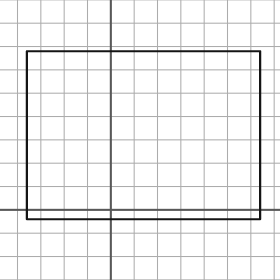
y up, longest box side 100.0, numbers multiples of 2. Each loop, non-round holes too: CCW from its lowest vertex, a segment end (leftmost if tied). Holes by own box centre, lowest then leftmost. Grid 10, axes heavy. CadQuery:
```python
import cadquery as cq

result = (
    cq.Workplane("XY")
    .moveTo(-36.0, -4.0)
    .lineTo(64.0, -4.0)
    .lineTo(64.0, 68.0)
    .lineTo(-36.0, 68.0)
    .close()
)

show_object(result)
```